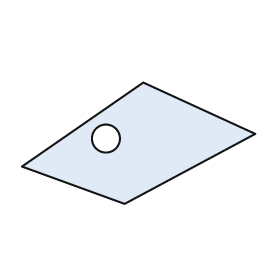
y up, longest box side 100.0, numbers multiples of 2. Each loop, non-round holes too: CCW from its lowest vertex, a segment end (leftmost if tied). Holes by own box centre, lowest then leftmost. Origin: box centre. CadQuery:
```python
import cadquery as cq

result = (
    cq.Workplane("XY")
    .moveTo(-6.0, -26.0)
    .lineTo(50.0, 4.0)
    .lineTo(2.0, 26.0)
    .lineTo(-50.0, -10.0)
    .close()
    .moveTo(-14.0, 2.0)
    .circle(6.0)
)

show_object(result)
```